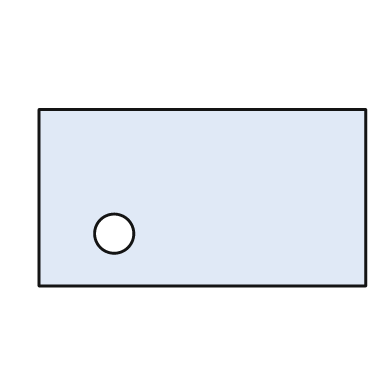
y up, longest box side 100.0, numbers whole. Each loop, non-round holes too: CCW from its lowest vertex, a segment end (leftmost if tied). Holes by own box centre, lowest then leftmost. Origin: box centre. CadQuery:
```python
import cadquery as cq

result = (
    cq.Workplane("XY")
    .moveTo(-50.0, -27.0)
    .lineTo(50.0, -27.0)
    .lineTo(50.0, 27.0)
    .lineTo(-50.0, 27.0)
    .close()
    .moveTo(-27.0, -11.0)
    .circle(6.0)
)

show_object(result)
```